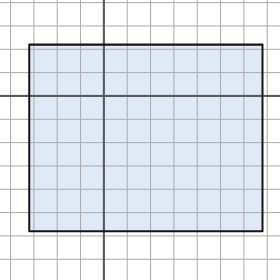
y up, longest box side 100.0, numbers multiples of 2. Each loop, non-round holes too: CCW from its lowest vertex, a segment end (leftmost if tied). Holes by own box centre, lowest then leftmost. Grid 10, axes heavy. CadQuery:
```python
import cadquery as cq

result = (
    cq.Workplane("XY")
    .moveTo(-32.0, -58.0)
    .lineTo(68.0, -58.0)
    .lineTo(68.0, 22.0)
    .lineTo(-32.0, 22.0)
    .close()
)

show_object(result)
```